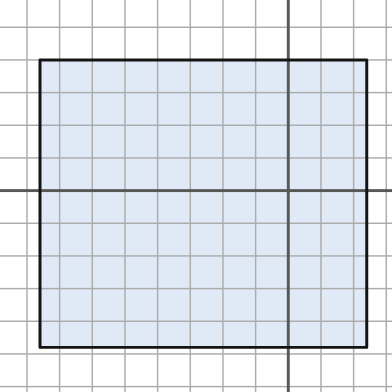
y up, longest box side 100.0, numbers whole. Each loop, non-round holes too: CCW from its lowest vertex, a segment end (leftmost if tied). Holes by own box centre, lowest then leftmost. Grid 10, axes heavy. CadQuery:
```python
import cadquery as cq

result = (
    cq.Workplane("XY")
    .moveTo(-76.0, -48.0)
    .lineTo(24.0, -48.0)
    .lineTo(24.0, 40.0)
    .lineTo(-76.0, 40.0)
    .close()
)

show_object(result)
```